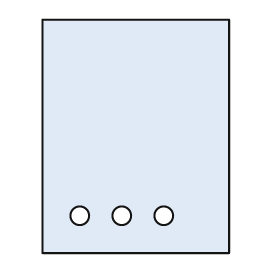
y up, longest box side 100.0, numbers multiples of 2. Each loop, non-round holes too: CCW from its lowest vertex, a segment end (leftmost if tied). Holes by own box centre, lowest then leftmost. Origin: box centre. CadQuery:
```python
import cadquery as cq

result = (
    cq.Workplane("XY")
    .moveTo(-40.0, -50.0)
    .lineTo(40.0, -50.0)
    .lineTo(40.0, 50.0)
    .lineTo(-40.0, 50.0)
    .close()
    .moveTo(-24.0, -34.0)
    .circle(4.0)
    .moveTo(-6.0, -34.0)
    .circle(4.0)
    .moveTo(12.0, -34.0)
    .circle(4.0)
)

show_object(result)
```